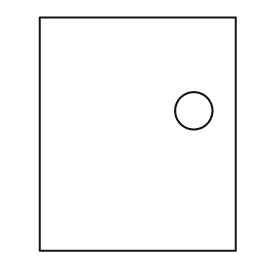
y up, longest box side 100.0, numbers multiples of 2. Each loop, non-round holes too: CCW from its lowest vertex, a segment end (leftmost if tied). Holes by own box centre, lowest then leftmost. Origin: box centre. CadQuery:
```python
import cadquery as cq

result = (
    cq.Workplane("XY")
    .moveTo(-42.0, -50.0)
    .lineTo(42.0, -50.0)
    .lineTo(42.0, 50.0)
    .lineTo(-42.0, 50.0)
    .close()
    .moveTo(24.0, 10.0)
    .circle(8.0)
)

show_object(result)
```